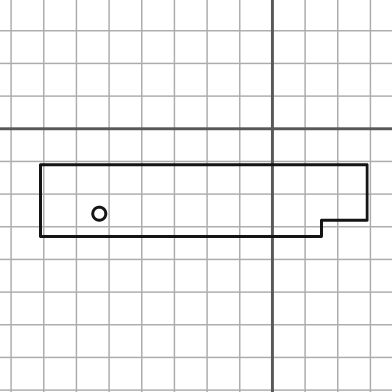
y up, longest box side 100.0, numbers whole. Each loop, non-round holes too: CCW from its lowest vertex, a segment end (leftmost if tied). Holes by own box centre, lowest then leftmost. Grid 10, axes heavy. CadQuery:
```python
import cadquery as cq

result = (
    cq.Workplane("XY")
    .moveTo(-71.0, -33.0)
    .lineTo(15.0, -33.0)
    .lineTo(15.0, -28.0)
    .lineTo(29.0, -28.0)
    .lineTo(29.0, -11.0)
    .lineTo(-71.0, -11.0)
    .close()
    .moveTo(-53.0, -26.0)
    .circle(2.0)
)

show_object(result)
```